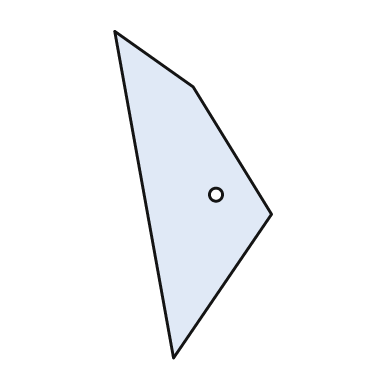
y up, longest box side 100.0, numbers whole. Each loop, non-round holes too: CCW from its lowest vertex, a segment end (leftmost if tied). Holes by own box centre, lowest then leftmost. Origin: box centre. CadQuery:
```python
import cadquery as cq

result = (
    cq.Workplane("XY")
    .moveTo(-6.0, -50.0)
    .lineTo(24.0, -6.0)
    .lineTo(0.0, 33.0)
    .lineTo(-24.0, 50.0)
    .close()
    .moveTo(7.0, 0.0)
    .circle(2.0)
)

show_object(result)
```